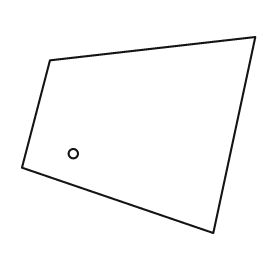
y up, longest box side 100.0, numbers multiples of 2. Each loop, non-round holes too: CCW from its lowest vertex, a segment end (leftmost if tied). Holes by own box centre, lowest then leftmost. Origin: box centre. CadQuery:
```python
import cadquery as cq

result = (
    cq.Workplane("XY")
    .moveTo(32.0, -42.0)
    .lineTo(50.0, 42.0)
    .lineTo(-38.0, 32.0)
    .lineTo(-50.0, -14.0)
    .close()
    .moveTo(-28.0, -8.0)
    .circle(2.0)
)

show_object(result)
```